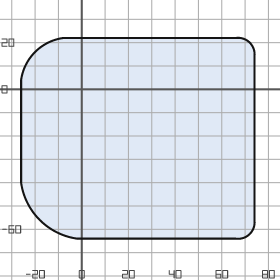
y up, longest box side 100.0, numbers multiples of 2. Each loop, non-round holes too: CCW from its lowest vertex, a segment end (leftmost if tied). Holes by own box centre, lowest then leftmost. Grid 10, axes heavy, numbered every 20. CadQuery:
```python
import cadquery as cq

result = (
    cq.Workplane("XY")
    .moveTo(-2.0, -64.0)
    .lineTo(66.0, -64.0)
    .threePointArc((72.0, -62.0), (74.0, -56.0))
    .lineTo(74.0, 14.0)
    .threePointArc((72.0, 20.0), (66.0, 22.0))
    .lineTo(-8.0, 22.0)
    .threePointArc((-20.0, 16.0), (-26.0, 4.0))
    .lineTo(-26.0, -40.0)
    .threePointArc((-18.0, -56.0), (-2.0, -64.0))
    .close()
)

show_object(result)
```